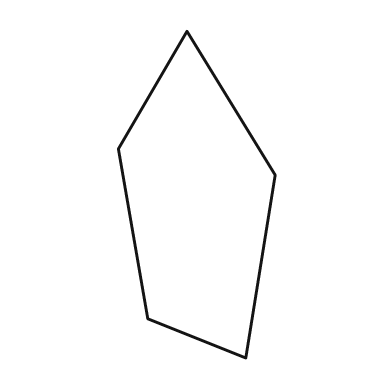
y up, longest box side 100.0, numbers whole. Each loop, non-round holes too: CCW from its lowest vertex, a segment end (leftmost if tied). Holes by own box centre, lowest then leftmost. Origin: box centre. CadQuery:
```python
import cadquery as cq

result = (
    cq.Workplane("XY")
    .moveTo(15.0, -50.0)
    .lineTo(24.0, 6.0)
    .lineTo(-3.0, 50.0)
    .lineTo(-24.0, 14.0)
    .lineTo(-15.0, -38.0)
    .close()
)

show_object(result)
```